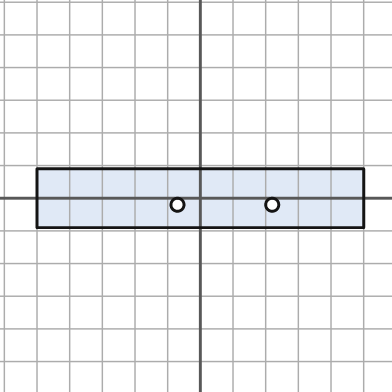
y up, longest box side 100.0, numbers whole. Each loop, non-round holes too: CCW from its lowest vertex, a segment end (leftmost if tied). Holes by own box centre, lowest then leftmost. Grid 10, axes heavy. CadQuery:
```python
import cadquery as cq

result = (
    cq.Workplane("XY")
    .moveTo(-50.0, -9.0)
    .lineTo(50.0, -9.0)
    .lineTo(50.0, 9.0)
    .lineTo(-50.0, 9.0)
    .close()
    .moveTo(-7.0, -2.0)
    .circle(2.0)
    .moveTo(22.0, -2.0)
    .circle(2.0)
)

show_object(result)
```